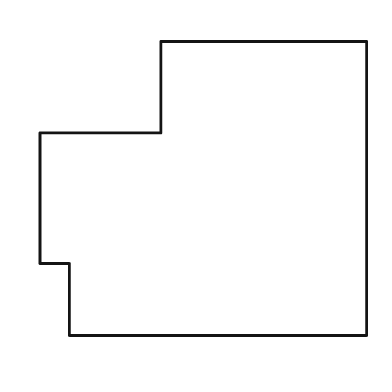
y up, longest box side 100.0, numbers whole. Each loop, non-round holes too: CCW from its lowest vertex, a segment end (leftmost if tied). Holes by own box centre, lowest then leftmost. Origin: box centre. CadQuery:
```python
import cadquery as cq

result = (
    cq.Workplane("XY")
    .moveTo(-41.0, -45.0)
    .lineTo(50.0, -45.0)
    .lineTo(50.0, 45.0)
    .lineTo(-13.0, 45.0)
    .lineTo(-13.0, 17.0)
    .lineTo(-50.0, 17.0)
    .lineTo(-50.0, -23.0)
    .lineTo(-41.0, -23.0)
    .close()
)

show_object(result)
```